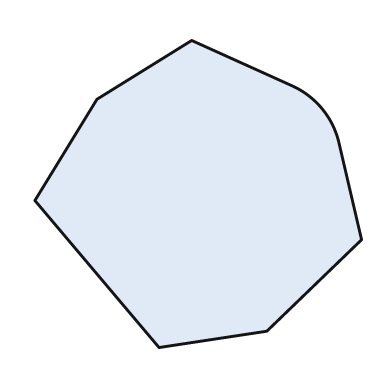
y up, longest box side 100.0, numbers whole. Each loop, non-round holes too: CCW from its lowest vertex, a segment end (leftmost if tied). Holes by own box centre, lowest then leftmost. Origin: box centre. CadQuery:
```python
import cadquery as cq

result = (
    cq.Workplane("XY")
    .moveTo(-12.0, -47.0)
    .lineTo(21.0, -42.0)
    .lineTo(50.0, -14.0)
    .lineTo(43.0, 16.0)
    .threePointArc((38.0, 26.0), (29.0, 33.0))
    .lineTo(-2.0, 47.0)
    .lineTo(-31.0, 29.0)
    .lineTo(-50.0, -2.0)
    .close()
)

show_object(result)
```